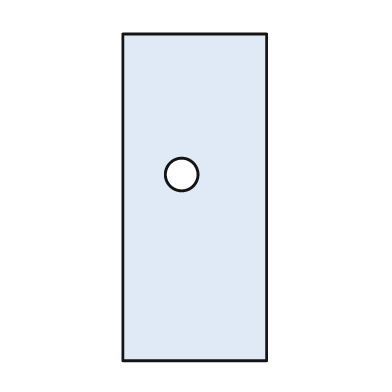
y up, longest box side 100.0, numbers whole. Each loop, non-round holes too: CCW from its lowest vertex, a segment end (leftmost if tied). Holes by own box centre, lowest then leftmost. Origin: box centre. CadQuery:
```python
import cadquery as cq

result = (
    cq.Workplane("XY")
    .moveTo(-22.0, -50.0)
    .lineTo(22.0, -50.0)
    .lineTo(22.0, 50.0)
    .lineTo(-22.0, 50.0)
    .close()
    .moveTo(-4.0, 7.0)
    .circle(5.0)
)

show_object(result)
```